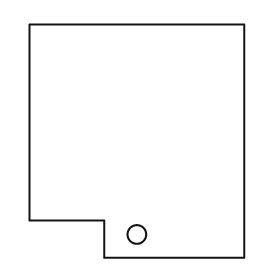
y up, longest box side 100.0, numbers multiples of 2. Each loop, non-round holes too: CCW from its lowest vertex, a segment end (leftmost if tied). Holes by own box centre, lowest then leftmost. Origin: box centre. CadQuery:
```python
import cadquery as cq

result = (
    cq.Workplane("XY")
    .moveTo(-14.0, -50.0)
    .lineTo(46.0, -50.0)
    .lineTo(46.0, 50.0)
    .lineTo(-46.0, 50.0)
    .lineTo(-46.0, -34.0)
    .lineTo(-14.0, -34.0)
    .close()
    .moveTo(0.0, -40.0)
    .circle(4.0)
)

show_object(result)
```